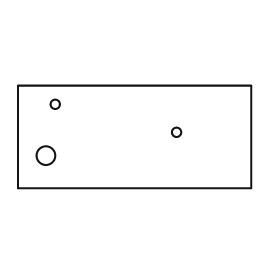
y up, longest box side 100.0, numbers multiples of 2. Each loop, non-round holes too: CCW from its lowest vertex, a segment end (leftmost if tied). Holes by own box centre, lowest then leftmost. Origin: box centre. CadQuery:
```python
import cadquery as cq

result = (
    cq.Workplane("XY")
    .moveTo(-50.0, -22.0)
    .lineTo(50.0, -22.0)
    .lineTo(50.0, 22.0)
    .lineTo(-50.0, 22.0)
    .close()
    .moveTo(-38.0, -8.0)
    .circle(4.0)
    .moveTo(18.0, 2.0)
    .circle(2.0)
    .moveTo(-34.0, 14.0)
    .circle(2.0)
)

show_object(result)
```